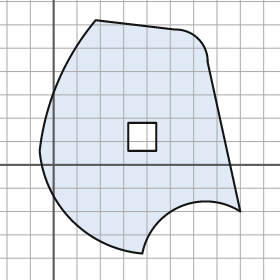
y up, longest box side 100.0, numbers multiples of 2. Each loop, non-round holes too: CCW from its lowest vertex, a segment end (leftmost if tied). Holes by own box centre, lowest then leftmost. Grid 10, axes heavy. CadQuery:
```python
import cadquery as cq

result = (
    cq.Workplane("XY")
    .moveTo(38.0, -38.0)
    .threePointArc((54.0, -18.0), (80.0, -20.0))
    .lineTo(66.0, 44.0)
    .threePointArc((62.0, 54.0), (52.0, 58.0))
    .lineTo(18.0, 62.0)
    .threePointArc((2.0, 36.0), (-6.0, 6.0))
    .threePointArc((8.0, -24.0), (38.0, -38.0))
    .close()
    .moveTo(32.0, 6.0)
    .lineTo(44.0, 6.0)
    .lineTo(44.0, 18.0)
    .lineTo(32.0, 18.0)
    .close()
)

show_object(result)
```